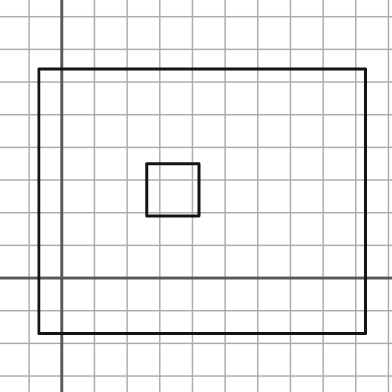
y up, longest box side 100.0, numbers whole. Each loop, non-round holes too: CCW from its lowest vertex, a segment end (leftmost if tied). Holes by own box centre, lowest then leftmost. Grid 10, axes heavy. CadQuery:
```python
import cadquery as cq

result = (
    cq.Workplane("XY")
    .moveTo(-7.0, -17.0)
    .lineTo(93.0, -17.0)
    .lineTo(93.0, 64.0)
    .lineTo(-7.0, 64.0)
    .close()
    .moveTo(26.0, 19.0)
    .lineTo(42.0, 19.0)
    .lineTo(42.0, 35.0)
    .lineTo(26.0, 35.0)
    .close()
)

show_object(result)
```